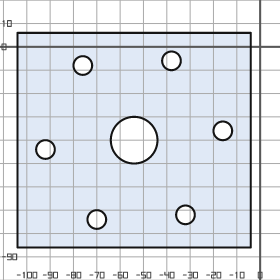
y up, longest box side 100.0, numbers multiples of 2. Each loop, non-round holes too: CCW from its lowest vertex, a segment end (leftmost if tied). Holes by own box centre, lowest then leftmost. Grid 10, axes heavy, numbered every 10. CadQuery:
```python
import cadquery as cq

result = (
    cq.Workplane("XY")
    .moveTo(-104.0, -86.0)
    .lineTo(-4.0, -86.0)
    .lineTo(-4.0, 6.0)
    .lineTo(-104.0, 6.0)
    .close()
    .moveTo(-70.0, -74.0)
    .circle(4.0)
    .moveTo(-32.0, -72.0)
    .circle(4.0)
    .moveTo(-92.0, -44.0)
    .circle(4.0)
    .moveTo(-54.0, -40.0)
    .circle(10.0)
    .moveTo(-16.0, -36.0)
    .circle(4.0)
    .moveTo(-76.0, -8.0)
    .circle(4.0)
    .moveTo(-38.0, -6.0)
    .circle(4.0)
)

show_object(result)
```